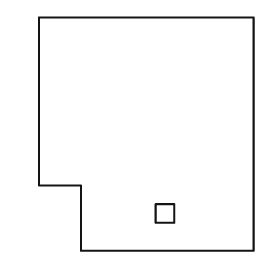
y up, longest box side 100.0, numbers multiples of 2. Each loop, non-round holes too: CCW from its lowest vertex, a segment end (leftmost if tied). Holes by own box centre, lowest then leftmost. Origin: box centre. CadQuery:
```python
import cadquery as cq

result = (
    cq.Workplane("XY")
    .moveTo(-28.0, -50.0)
    .lineTo(46.0, -50.0)
    .lineTo(46.0, 50.0)
    .lineTo(-46.0, 50.0)
    .lineTo(-46.0, -22.0)
    .lineTo(-28.0, -22.0)
    .close()
    .moveTo(4.0, -38.0)
    .lineTo(12.0, -38.0)
    .lineTo(12.0, -30.0)
    .lineTo(4.0, -30.0)
    .close()
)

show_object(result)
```